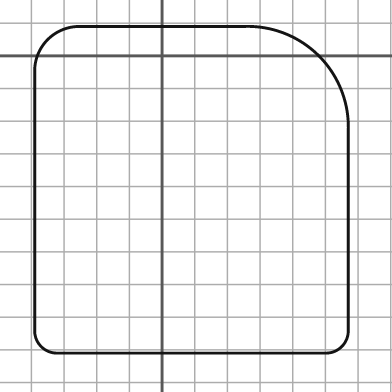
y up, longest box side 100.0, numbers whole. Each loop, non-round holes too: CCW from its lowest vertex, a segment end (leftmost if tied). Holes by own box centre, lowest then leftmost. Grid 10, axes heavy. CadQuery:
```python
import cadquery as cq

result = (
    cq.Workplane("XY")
    .moveTo(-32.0, -91.0)
    .lineTo(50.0, -91.0)
    .threePointArc((55.0, -89.0), (57.0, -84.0))
    .lineTo(57.0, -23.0)
    .threePointArc((48.0, 0.0), (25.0, 9.0))
    .lineTo(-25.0, 9.0)
    .threePointArc((-35.0, 5.0), (-39.0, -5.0))
    .lineTo(-39.0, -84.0)
    .threePointArc((-37.0, -89.0), (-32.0, -91.0))
    .close()
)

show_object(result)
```